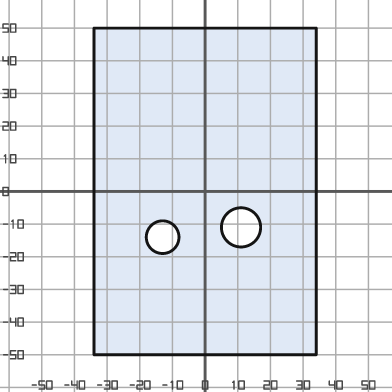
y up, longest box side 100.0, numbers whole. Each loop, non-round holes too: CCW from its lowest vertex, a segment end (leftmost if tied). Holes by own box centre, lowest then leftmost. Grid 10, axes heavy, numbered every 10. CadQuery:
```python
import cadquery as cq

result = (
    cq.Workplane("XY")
    .moveTo(-34.0, -50.0)
    .lineTo(34.0, -50.0)
    .lineTo(34.0, 50.0)
    .lineTo(-34.0, 50.0)
    .close()
    .moveTo(-13.0, -14.0)
    .circle(5.0)
    .moveTo(11.0, -11.0)
    .circle(6.0)
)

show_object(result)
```